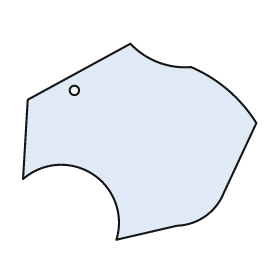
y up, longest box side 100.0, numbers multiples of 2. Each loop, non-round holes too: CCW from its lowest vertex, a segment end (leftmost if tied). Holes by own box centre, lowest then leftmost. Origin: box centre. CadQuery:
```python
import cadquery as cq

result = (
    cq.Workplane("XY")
    .moveTo(-10.0, -42.0)
    .lineTo(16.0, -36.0)
    .threePointArc((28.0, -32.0), (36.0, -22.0))
    .lineTo(50.0, 8.0)
    .threePointArc((38.0, 22.0), (22.0, 32.0))
    .threePointArc((8.0, 34.0), (-4.0, 42.0))
    .lineTo(-48.0, 18.0)
    .lineTo(-50.0, -16.0)
    .threePointArc((-20.0, -14.0), (-10.0, -42.0))
    .close()
    .moveTo(-28.0, 22.0)
    .circle(2.0)
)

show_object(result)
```